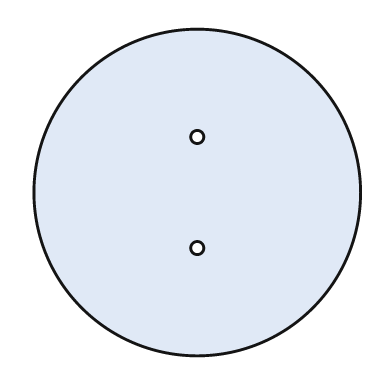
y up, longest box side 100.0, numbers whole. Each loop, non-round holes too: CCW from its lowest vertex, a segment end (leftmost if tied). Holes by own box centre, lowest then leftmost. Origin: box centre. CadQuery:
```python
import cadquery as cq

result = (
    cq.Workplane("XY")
    .moveTo(0.0, 0.0)
    .circle(50.0)
    .moveTo(0.0, -17.0)
    .circle(2.0)
    .moveTo(0.0, 17.0)
    .circle(2.0)
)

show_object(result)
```